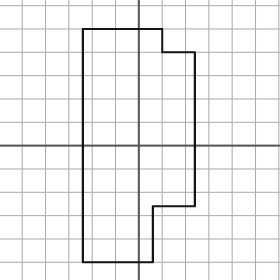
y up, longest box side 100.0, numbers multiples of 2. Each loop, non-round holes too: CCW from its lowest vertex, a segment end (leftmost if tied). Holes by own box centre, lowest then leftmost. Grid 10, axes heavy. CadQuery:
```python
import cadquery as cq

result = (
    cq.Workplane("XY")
    .moveTo(-24.0, -50.0)
    .lineTo(6.0, -50.0)
    .lineTo(6.0, -26.0)
    .lineTo(24.0, -26.0)
    .lineTo(24.0, 40.0)
    .lineTo(10.0, 40.0)
    .lineTo(10.0, 50.0)
    .lineTo(-24.0, 50.0)
    .close()
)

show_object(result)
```